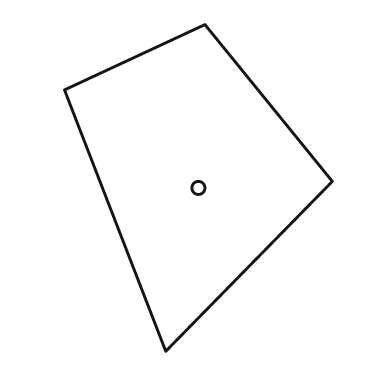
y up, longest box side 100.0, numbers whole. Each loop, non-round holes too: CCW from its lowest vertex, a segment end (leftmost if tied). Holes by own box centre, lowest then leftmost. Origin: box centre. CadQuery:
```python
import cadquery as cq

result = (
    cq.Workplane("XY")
    .moveTo(-10.0, -50.0)
    .lineTo(41.0, 2.0)
    .lineTo(2.0, 50.0)
    .lineTo(-41.0, 30.0)
    .close()
    .moveTo(0.0, 0.0)
    .circle(2.0)
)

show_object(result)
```